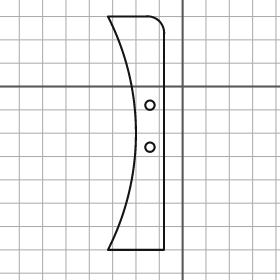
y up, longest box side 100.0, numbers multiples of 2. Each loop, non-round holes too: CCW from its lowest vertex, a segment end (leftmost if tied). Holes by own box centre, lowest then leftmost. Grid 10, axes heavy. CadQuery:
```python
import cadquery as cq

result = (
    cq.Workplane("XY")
    .moveTo(-32.0, -70.0)
    .lineTo(-8.0, -70.0)
    .lineTo(-8.0, 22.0)
    .threePointArc((-10.0, 28.0), (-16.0, 30.0))
    .lineTo(-32.0, 30.0)
    .threePointArc((-20.0, -20.0), (-32.0, -70.0))
    .close()
    .moveTo(-14.0, -26.0)
    .circle(2.0)
    .moveTo(-14.0, -8.0)
    .circle(2.0)
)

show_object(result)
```